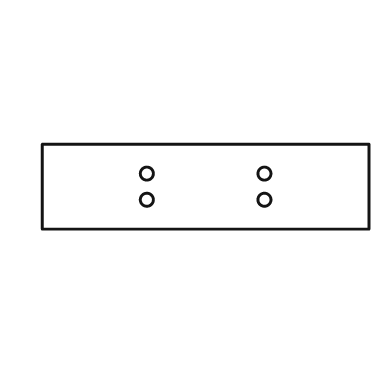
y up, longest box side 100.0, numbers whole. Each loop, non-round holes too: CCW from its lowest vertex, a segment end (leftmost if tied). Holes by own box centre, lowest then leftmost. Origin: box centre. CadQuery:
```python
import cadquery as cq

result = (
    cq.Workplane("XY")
    .moveTo(-50.0, -13.0)
    .lineTo(50.0, -13.0)
    .lineTo(50.0, 13.0)
    .lineTo(-50.0, 13.0)
    .close()
    .moveTo(-18.0, -4.0)
    .circle(2.0)
    .moveTo(18.0, -4.0)
    .circle(2.0)
    .moveTo(-18.0, 4.0)
    .circle(2.0)
    .moveTo(18.0, 4.0)
    .circle(2.0)
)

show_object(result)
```